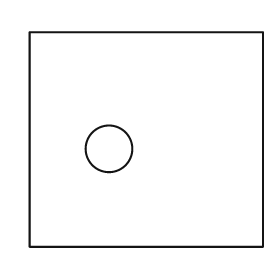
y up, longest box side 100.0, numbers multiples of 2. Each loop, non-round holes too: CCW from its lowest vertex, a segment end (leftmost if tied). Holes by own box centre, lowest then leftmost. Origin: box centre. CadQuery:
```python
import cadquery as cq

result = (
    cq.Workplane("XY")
    .moveTo(-50.0, -46.0)
    .lineTo(50.0, -46.0)
    .lineTo(50.0, 46.0)
    .lineTo(-50.0, 46.0)
    .close()
    .moveTo(-16.0, -4.0)
    .circle(10.0)
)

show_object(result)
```